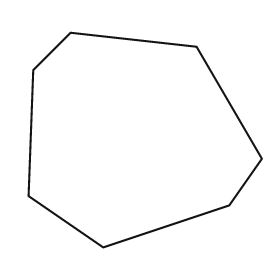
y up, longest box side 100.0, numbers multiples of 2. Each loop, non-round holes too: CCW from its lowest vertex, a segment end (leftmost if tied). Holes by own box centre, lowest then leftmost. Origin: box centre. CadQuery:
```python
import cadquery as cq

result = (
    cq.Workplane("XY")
    .moveTo(-18.0, -46.0)
    .lineTo(36.0, -28.0)
    .lineTo(50.0, -8.0)
    .lineTo(22.0, 40.0)
    .lineTo(-32.0, 46.0)
    .lineTo(-48.0, 30.0)
    .lineTo(-50.0, -24.0)
    .close()
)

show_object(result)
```